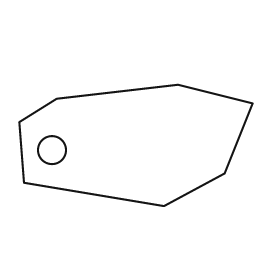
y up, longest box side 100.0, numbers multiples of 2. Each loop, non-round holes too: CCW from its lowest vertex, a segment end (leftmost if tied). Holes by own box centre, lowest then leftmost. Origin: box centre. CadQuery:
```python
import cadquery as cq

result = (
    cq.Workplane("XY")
    .moveTo(12.0, -26.0)
    .lineTo(38.0, -12.0)
    .lineTo(50.0, 18.0)
    .lineTo(18.0, 26.0)
    .lineTo(-34.0, 20.0)
    .lineTo(-50.0, 10.0)
    .lineTo(-48.0, -16.0)
    .close()
    .moveTo(-36.0, -2.0)
    .circle(6.0)
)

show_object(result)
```